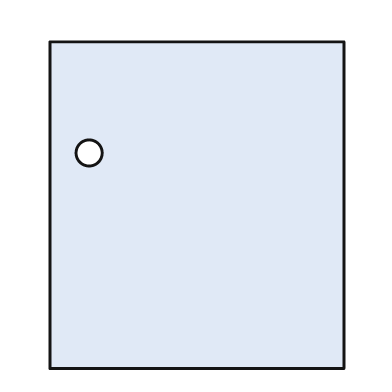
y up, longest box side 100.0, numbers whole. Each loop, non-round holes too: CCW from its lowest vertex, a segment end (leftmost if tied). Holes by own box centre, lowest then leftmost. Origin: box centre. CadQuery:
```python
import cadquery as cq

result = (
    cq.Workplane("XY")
    .moveTo(-45.0, -50.0)
    .lineTo(45.0, -50.0)
    .lineTo(45.0, 50.0)
    .lineTo(-45.0, 50.0)
    .close()
    .moveTo(-33.0, 16.0)
    .circle(4.0)
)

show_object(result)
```